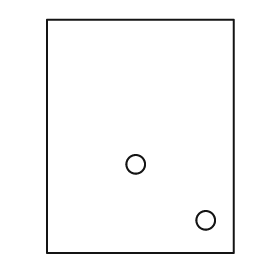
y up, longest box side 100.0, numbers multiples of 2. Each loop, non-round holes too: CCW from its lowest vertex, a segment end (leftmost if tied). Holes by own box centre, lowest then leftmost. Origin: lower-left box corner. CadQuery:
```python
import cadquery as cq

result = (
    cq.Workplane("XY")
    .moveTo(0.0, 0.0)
    .lineTo(80.0, 0.0)
    .lineTo(80.0, 100.0)
    .lineTo(0.0, 100.0)
    .close()
    .moveTo(68.0, 14.0)
    .circle(4.0)
    .moveTo(38.0, 38.0)
    .circle(4.0)
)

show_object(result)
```